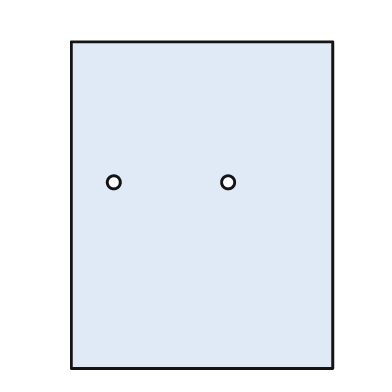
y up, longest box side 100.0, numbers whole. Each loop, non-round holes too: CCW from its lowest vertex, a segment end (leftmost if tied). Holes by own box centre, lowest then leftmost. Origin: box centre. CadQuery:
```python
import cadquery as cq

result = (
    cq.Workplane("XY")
    .moveTo(-40.0, -50.0)
    .lineTo(40.0, -50.0)
    .lineTo(40.0, 50.0)
    .lineTo(-40.0, 50.0)
    .close()
    .moveTo(-27.0, 7.0)
    .circle(2.0)
    .moveTo(8.0, 7.0)
    .circle(2.0)
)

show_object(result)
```